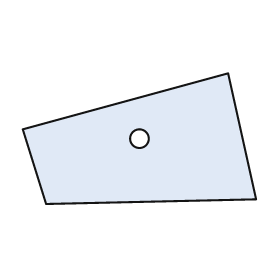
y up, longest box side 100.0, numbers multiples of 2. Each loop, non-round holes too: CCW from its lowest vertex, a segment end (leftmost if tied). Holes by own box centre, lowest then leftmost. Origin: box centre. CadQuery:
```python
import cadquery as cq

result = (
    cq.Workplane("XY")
    .moveTo(-40.0, -28.0)
    .lineTo(50.0, -26.0)
    .lineTo(38.0, 28.0)
    .lineTo(-50.0, 4.0)
    .close()
    .moveTo(0.0, 0.0)
    .circle(4.0)
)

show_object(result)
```